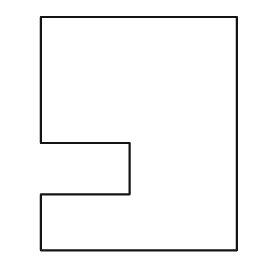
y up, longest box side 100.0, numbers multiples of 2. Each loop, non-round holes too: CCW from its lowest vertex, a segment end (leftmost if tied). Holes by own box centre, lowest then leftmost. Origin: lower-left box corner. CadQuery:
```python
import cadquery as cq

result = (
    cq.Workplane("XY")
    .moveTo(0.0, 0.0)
    .lineTo(84.0, 0.0)
    .lineTo(84.0, 100.0)
    .lineTo(0.0, 100.0)
    .lineTo(0.0, 46.0)
    .lineTo(38.0, 46.0)
    .lineTo(38.0, 24.0)
    .lineTo(0.0, 24.0)
    .close()
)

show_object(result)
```